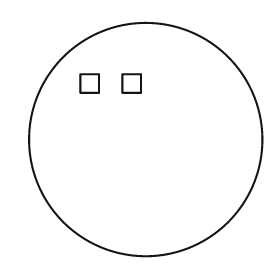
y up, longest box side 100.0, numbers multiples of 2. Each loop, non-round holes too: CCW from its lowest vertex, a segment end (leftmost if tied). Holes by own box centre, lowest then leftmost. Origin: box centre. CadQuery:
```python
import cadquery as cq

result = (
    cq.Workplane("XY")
    .moveTo(0.0, 0.0)
    .circle(50.0)
    .moveTo(-28.0, 20.0)
    .lineTo(-20.0, 20.0)
    .lineTo(-20.0, 28.0)
    .lineTo(-28.0, 28.0)
    .close()
    .moveTo(-10.0, 20.0)
    .lineTo(-2.0, 20.0)
    .lineTo(-2.0, 28.0)
    .lineTo(-10.0, 28.0)
    .close()
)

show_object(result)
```